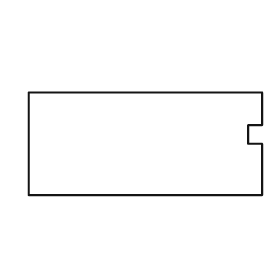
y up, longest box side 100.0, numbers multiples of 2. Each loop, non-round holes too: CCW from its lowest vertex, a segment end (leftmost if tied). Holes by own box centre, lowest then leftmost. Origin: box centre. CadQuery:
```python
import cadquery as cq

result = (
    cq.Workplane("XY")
    .moveTo(-50.0, -22.0)
    .lineTo(50.0, -22.0)
    .lineTo(50.0, 0.0)
    .lineTo(44.0, 0.0)
    .lineTo(44.0, 8.0)
    .lineTo(50.0, 8.0)
    .lineTo(50.0, 22.0)
    .lineTo(-50.0, 22.0)
    .close()
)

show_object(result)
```